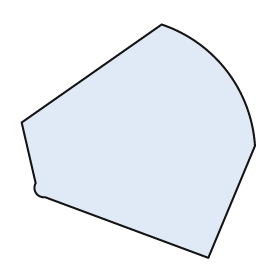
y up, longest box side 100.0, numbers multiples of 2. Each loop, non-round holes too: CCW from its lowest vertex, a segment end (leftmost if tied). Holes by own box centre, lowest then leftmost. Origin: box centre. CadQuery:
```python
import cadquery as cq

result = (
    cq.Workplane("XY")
    .moveTo(30.0, -50.0)
    .lineTo(50.0, -2.0)
    .threePointArc((38.0, 30.0), (10.0, 50.0))
    .lineTo(-50.0, 8.0)
    .lineTo(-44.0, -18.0)
    .threePointArc((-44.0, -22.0), (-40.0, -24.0))
    .close()
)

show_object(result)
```